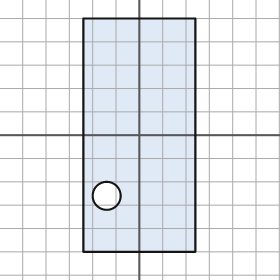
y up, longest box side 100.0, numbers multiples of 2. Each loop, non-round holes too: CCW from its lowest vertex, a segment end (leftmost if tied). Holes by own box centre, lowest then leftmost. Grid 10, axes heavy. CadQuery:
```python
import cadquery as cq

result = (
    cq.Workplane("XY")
    .moveTo(-24.0, -50.0)
    .lineTo(24.0, -50.0)
    .lineTo(24.0, 50.0)
    .lineTo(-24.0, 50.0)
    .close()
    .moveTo(-14.0, -26.0)
    .circle(6.0)
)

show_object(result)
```